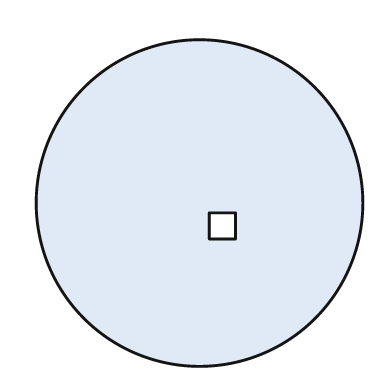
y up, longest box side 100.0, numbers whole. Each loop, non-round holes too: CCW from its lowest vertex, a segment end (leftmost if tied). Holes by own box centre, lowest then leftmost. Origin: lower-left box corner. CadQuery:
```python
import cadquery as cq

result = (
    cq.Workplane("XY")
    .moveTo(50.0, 50.0)
    .circle(50.0)
    .moveTo(53.0, 39.0)
    .lineTo(61.0, 39.0)
    .lineTo(61.0, 47.0)
    .lineTo(53.0, 47.0)
    .close()
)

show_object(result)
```